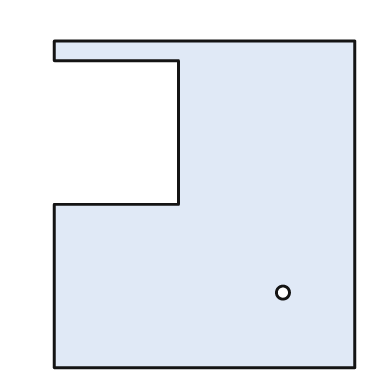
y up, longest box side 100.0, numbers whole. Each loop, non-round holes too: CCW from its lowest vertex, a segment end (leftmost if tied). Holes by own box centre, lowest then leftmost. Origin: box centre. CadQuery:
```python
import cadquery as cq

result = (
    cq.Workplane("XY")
    .moveTo(-46.0, -50.0)
    .lineTo(46.0, -50.0)
    .lineTo(46.0, 50.0)
    .lineTo(-46.0, 50.0)
    .lineTo(-46.0, 44.0)
    .lineTo(-8.0, 44.0)
    .lineTo(-8.0, 0.0)
    .lineTo(-46.0, 0.0)
    .close()
    .moveTo(24.0, -27.0)
    .circle(2.0)
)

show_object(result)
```